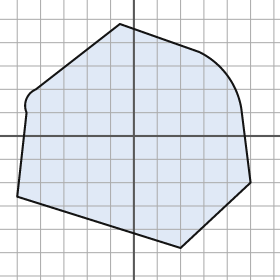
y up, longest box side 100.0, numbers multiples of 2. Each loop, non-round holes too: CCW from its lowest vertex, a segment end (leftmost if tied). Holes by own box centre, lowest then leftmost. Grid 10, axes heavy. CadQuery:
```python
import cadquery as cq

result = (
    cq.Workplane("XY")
    .moveTo(20.0, -48.0)
    .lineTo(50.0, -20.0)
    .lineTo(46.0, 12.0)
    .threePointArc((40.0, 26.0), (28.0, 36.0))
    .lineTo(-6.0, 48.0)
    .lineTo(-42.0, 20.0)
    .threePointArc((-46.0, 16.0), (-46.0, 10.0))
    .lineTo(-50.0, -26.0)
    .close()
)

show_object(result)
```